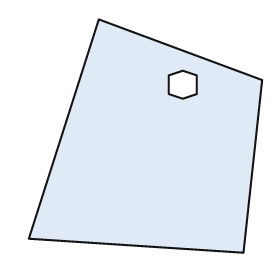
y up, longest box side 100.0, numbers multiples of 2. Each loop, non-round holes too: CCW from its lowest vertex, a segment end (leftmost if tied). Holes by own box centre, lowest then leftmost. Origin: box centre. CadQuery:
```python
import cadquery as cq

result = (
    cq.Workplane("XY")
    .moveTo(42.0, -50.0)
    .lineTo(50.0, 24.0)
    .lineTo(-20.0, 50.0)
    .lineTo(-50.0, -44.0)
    .close()
    .moveTo(16.0, 16.0)
    .lineTo(22.0, 18.0)
    .lineTo(22.0, 26.0)
    .lineTo(16.0, 28.0)
    .lineTo(10.0, 26.0)
    .lineTo(10.0, 18.0)
    .close()
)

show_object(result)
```